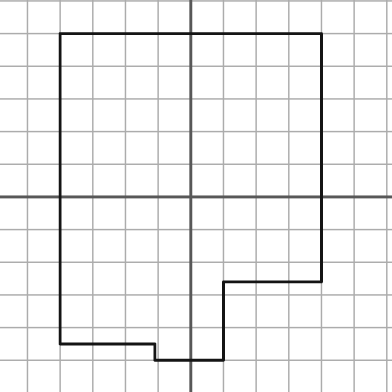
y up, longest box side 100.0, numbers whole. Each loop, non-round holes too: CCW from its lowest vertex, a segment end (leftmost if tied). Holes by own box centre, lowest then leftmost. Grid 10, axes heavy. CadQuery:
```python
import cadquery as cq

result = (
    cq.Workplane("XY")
    .moveTo(-11.0, -50.0)
    .lineTo(10.0, -50.0)
    .lineTo(10.0, -26.0)
    .lineTo(40.0, -26.0)
    .lineTo(40.0, 50.0)
    .lineTo(-40.0, 50.0)
    .lineTo(-40.0, -45.0)
    .lineTo(-11.0, -45.0)
    .close()
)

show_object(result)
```